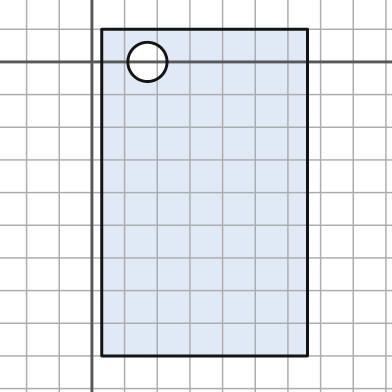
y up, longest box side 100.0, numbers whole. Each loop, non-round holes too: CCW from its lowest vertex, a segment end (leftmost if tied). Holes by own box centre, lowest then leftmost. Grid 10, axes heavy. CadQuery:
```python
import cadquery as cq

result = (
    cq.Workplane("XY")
    .moveTo(3.0, -90.0)
    .lineTo(66.0, -90.0)
    .lineTo(66.0, 10.0)
    .lineTo(3.0, 10.0)
    .close()
    .moveTo(17.0, 0.0)
    .circle(6.0)
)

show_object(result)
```